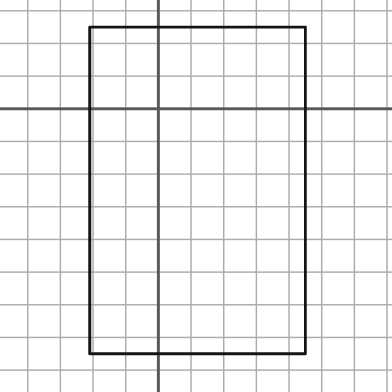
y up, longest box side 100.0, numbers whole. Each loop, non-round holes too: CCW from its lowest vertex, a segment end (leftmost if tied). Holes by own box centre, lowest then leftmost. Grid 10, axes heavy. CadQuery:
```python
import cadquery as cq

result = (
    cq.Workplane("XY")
    .moveTo(-21.0, -75.0)
    .lineTo(45.0, -75.0)
    .lineTo(45.0, 25.0)
    .lineTo(-21.0, 25.0)
    .close()
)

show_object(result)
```